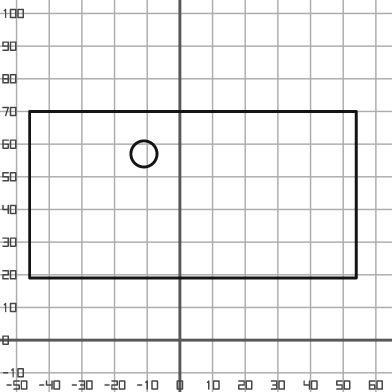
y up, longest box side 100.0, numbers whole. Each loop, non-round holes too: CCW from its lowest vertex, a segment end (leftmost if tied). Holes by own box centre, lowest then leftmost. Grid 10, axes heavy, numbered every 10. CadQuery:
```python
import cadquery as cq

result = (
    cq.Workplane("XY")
    .moveTo(-46.0, 19.0)
    .lineTo(54.0, 19.0)
    .lineTo(54.0, 70.0)
    .lineTo(-46.0, 70.0)
    .close()
    .moveTo(-11.0, 57.0)
    .circle(4.0)
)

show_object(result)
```